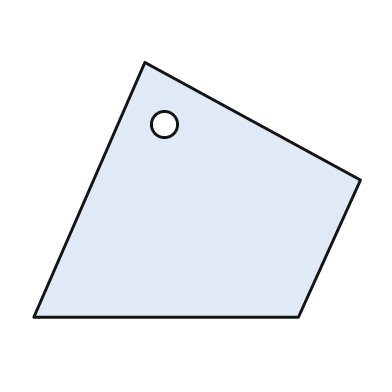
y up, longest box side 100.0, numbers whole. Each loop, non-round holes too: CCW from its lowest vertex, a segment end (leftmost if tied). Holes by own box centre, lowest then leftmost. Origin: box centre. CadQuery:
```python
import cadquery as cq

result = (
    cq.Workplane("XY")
    .moveTo(-50.0, -39.0)
    .lineTo(31.0, -39.0)
    .lineTo(50.0, 3.0)
    .lineTo(-16.0, 39.0)
    .close()
    .moveTo(-10.0, 20.0)
    .circle(4.0)
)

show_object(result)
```